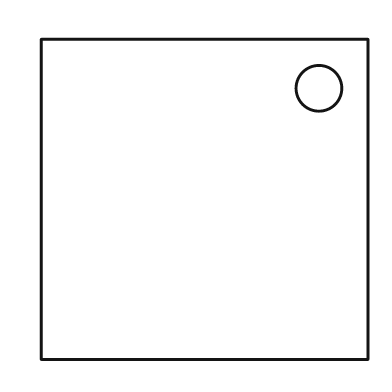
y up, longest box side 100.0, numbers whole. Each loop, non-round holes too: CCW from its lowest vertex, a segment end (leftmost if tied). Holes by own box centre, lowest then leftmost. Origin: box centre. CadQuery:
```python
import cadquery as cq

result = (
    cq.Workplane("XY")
    .moveTo(-50.0, -49.0)
    .lineTo(50.0, -49.0)
    .lineTo(50.0, 49.0)
    .lineTo(-50.0, 49.0)
    .close()
    .moveTo(35.0, 34.0)
    .circle(7.0)
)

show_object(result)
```